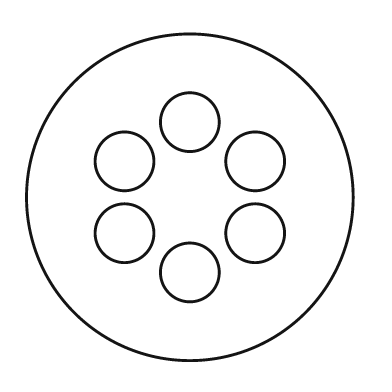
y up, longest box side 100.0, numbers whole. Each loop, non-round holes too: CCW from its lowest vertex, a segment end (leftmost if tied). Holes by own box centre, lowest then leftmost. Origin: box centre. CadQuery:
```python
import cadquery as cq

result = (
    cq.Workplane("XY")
    .moveTo(0.0, 0.0)
    .circle(50.0)
    .moveTo(0.0, -23.0)
    .circle(9.0)
    .moveTo(-20.0, -11.0)
    .circle(9.0)
    .moveTo(20.0, -11.0)
    .circle(9.0)
    .moveTo(-20.0, 11.0)
    .circle(9.0)
    .moveTo(20.0, 11.0)
    .circle(9.0)
    .moveTo(0.0, 23.0)
    .circle(9.0)
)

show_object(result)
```